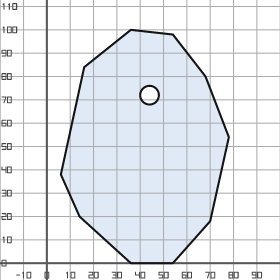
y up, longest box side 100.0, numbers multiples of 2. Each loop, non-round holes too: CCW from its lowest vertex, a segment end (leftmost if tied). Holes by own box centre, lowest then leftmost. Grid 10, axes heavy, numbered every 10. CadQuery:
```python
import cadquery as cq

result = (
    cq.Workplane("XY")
    .moveTo(36.0, 0.0)
    .lineTo(54.0, 0.0)
    .lineTo(70.0, 18.0)
    .lineTo(78.0, 54.0)
    .lineTo(68.0, 80.0)
    .lineTo(54.0, 98.0)
    .lineTo(36.0, 100.0)
    .lineTo(16.0, 84.0)
    .lineTo(6.0, 38.0)
    .lineTo(14.0, 20.0)
    .close()
    .moveTo(44.0, 72.0)
    .circle(4.0)
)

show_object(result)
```